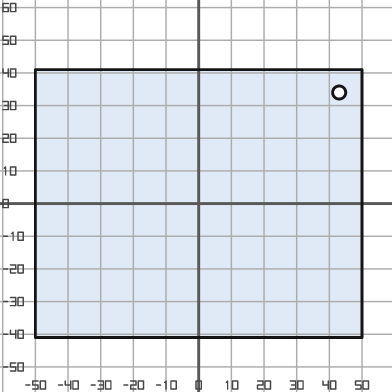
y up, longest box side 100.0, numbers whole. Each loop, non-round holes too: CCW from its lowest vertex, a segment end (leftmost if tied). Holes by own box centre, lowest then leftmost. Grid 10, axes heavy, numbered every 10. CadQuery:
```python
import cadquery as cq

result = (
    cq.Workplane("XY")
    .moveTo(-50.0, -41.0)
    .lineTo(50.0, -41.0)
    .lineTo(50.0, 41.0)
    .lineTo(-50.0, 41.0)
    .close()
    .moveTo(43.0, 34.0)
    .circle(2.0)
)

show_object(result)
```